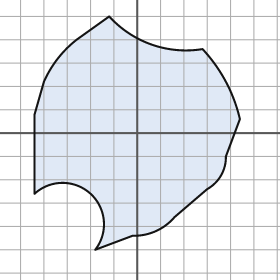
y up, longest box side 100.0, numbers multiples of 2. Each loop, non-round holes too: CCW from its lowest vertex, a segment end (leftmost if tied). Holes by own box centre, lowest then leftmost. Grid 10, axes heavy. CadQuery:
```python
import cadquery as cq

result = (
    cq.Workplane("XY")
    .moveTo(-18.0, -50.0)
    .lineTo(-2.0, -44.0)
    .threePointArc((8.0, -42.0), (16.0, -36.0))
    .lineTo(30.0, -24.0)
    .threePointArc((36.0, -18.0), (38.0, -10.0))
    .lineTo(44.0, 6.0)
    .threePointArc((38.0, 22.0), (28.0, 36.0))
    .threePointArc((6.0, 38.0), (-12.0, 50.0))
    .lineTo(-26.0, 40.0)
    .threePointArc((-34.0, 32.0), (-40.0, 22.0))
    .lineTo(-44.0, 8.0)
    .lineTo(-44.0, -26.0)
    .threePointArc((-20.0, -26.0), (-18.0, -50.0))
    .close()
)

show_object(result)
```